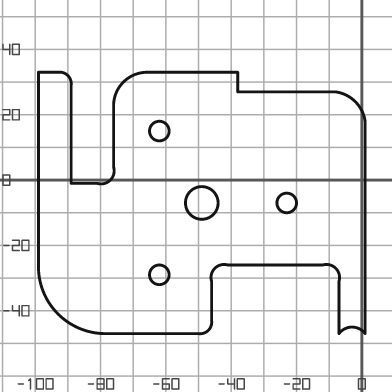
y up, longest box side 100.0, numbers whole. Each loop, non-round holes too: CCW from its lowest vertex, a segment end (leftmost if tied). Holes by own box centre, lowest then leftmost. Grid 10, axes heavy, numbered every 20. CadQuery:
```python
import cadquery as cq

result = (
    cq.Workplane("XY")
    .moveTo(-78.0, -47.0)
    .lineTo(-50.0, -47.0)
    .threePointArc((-47.0, -46.0), (-46.0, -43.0))
    .lineTo(-46.0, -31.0)
    .threePointArc((-45.0, -27.0), (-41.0, -26.0))
    .lineTo(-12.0, -26.0)
    .threePointArc((-8.0, -27.0), (-7.0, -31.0))
    .lineTo(-7.0, -47.0)
    .threePointArc((-3.0, -45.0), (1.0, -47.0))
    .lineTo(1.0, 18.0)
    .threePointArc((-2.0, 24.0), (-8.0, 27.0))
    .lineTo(-38.0, 27.0)
    .lineTo(-38.0, 33.0)
    .lineTo(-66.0, 33.0)
    .threePointArc((-73.0, 30.0), (-76.0, 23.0))
    .lineTo(-76.0, 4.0)
    .threePointArc((-77.0, 0.0), (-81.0, -1.0))
    .lineTo(-89.0, -1.0)
    .lineTo(-89.0, 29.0)
    .threePointArc((-90.0, 32.0), (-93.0, 33.0))
    .lineTo(-99.0, 33.0)
    .lineTo(-99.0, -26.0)
    .threePointArc((-93.0, -41.0), (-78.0, -47.0))
    .close()
    .moveTo(-62.0, -29.0)
    .circle(3.0)
    .moveTo(-49.0, -7.0)
    .circle(5.0)
    .moveTo(-23.0, -7.0)
    .circle(3.0)
    .moveTo(-62.0, 15.0)
    .circle(3.0)
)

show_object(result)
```